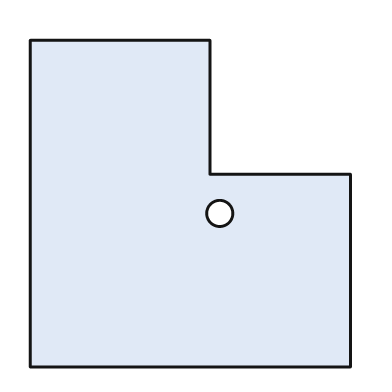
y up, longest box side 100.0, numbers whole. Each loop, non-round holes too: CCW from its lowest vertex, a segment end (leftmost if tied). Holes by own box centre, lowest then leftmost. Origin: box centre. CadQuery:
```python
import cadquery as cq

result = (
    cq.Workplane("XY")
    .moveTo(-49.0, -50.0)
    .lineTo(49.0, -50.0)
    .lineTo(49.0, 9.0)
    .lineTo(6.0, 9.0)
    .lineTo(6.0, 50.0)
    .lineTo(-49.0, 50.0)
    .close()
    .moveTo(9.0, -3.0)
    .circle(4.0)
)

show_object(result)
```